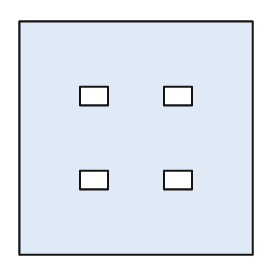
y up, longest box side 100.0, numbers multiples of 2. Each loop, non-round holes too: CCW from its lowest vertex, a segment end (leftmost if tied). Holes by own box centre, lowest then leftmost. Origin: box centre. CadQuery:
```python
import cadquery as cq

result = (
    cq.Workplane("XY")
    .moveTo(-50.0, -50.0)
    .lineTo(50.0, -50.0)
    .lineTo(50.0, 50.0)
    .lineTo(-50.0, 50.0)
    .close()
    .moveTo(-24.0, -22.0)
    .lineTo(-12.0, -22.0)
    .lineTo(-12.0, -14.0)
    .lineTo(-24.0, -14.0)
    .close()
    .moveTo(12.0, -22.0)
    .lineTo(24.0, -22.0)
    .lineTo(24.0, -14.0)
    .lineTo(12.0, -14.0)
    .close()
    .moveTo(-24.0, 14.0)
    .lineTo(-12.0, 14.0)
    .lineTo(-12.0, 22.0)
    .lineTo(-24.0, 22.0)
    .close()
    .moveTo(12.0, 14.0)
    .lineTo(24.0, 14.0)
    .lineTo(24.0, 22.0)
    .lineTo(12.0, 22.0)
    .close()
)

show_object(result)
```